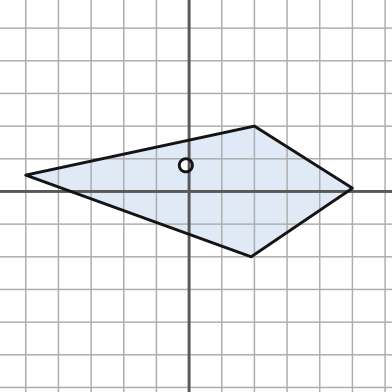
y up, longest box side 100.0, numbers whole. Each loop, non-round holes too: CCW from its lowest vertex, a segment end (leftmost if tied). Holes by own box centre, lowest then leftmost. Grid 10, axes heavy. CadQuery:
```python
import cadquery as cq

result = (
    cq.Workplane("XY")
    .moveTo(19.0, -20.0)
    .lineTo(50.0, 1.0)
    .lineTo(20.0, 20.0)
    .lineTo(-50.0, 5.0)
    .close()
    .moveTo(-1.0, 8.0)
    .circle(2.0)
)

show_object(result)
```